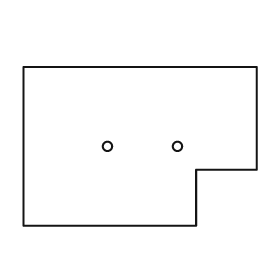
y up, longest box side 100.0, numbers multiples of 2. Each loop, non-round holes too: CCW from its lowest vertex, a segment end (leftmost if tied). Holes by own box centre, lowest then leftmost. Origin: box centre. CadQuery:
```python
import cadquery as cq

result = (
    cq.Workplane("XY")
    .moveTo(-50.0, -34.0)
    .lineTo(24.0, -34.0)
    .lineTo(24.0, -10.0)
    .lineTo(50.0, -10.0)
    .lineTo(50.0, 34.0)
    .lineTo(-50.0, 34.0)
    .close()
    .moveTo(-14.0, 0.0)
    .circle(2.0)
    .moveTo(16.0, 0.0)
    .circle(2.0)
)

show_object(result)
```